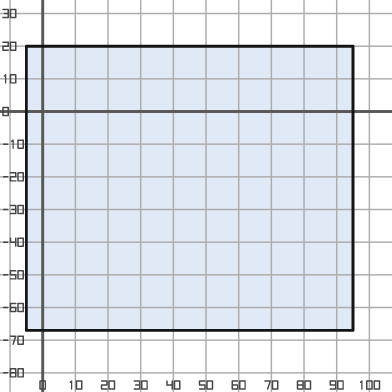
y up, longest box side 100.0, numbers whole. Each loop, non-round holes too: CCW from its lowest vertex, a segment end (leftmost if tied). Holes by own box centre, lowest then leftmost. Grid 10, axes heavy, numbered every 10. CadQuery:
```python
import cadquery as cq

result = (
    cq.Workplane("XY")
    .moveTo(-5.0, -67.0)
    .lineTo(95.0, -67.0)
    .lineTo(95.0, 20.0)
    .lineTo(-5.0, 20.0)
    .close()
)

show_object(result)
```